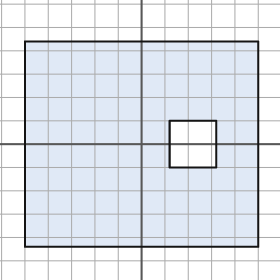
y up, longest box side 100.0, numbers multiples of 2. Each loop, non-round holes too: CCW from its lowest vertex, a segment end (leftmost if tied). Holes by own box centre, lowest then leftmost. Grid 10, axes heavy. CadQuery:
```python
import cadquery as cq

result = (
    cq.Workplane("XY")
    .moveTo(-50.0, -44.0)
    .lineTo(50.0, -44.0)
    .lineTo(50.0, 44.0)
    .lineTo(-50.0, 44.0)
    .close()
    .moveTo(12.0, -10.0)
    .lineTo(32.0, -10.0)
    .lineTo(32.0, 10.0)
    .lineTo(12.0, 10.0)
    .close()
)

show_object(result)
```